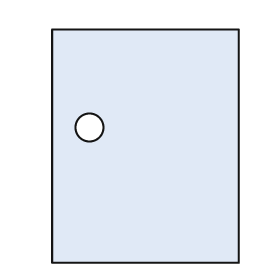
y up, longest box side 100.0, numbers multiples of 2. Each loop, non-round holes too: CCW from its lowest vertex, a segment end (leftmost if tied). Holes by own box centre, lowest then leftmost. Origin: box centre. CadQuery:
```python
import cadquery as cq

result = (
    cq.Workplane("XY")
    .moveTo(-40.0, -50.0)
    .lineTo(40.0, -50.0)
    .lineTo(40.0, 50.0)
    .lineTo(-40.0, 50.0)
    .close()
    .moveTo(-24.0, 8.0)
    .circle(6.0)
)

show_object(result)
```